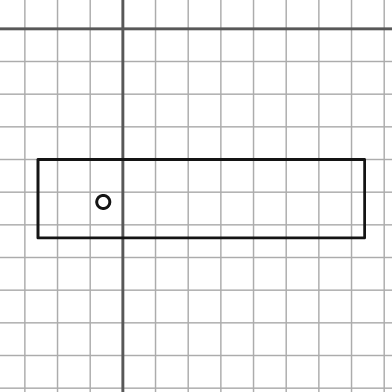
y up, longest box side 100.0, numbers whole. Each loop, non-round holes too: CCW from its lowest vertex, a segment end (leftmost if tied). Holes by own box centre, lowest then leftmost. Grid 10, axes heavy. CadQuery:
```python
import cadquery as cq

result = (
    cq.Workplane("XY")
    .moveTo(-26.0, -64.0)
    .lineTo(74.0, -64.0)
    .lineTo(74.0, -40.0)
    .lineTo(-26.0, -40.0)
    .close()
    .moveTo(-6.0, -53.0)
    .circle(2.0)
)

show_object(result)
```